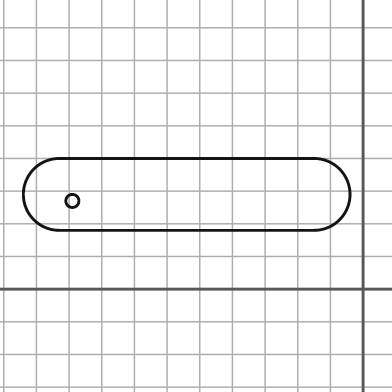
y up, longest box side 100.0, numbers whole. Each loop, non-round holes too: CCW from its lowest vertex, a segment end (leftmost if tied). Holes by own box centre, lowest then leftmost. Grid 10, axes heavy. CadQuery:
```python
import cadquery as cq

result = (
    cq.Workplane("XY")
    .moveTo(-93.0, 18.0)
    .lineTo(-15.0, 18.0)
    .threePointArc((-4.0, 29.0), (-15.0, 40.0))
    .lineTo(-93.0, 40.0)
    .threePointArc((-104.0, 29.0), (-93.0, 18.0))
    .close()
    .moveTo(-89.0, 27.0)
    .circle(2.0)
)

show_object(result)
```